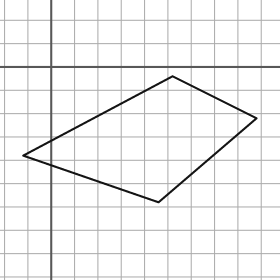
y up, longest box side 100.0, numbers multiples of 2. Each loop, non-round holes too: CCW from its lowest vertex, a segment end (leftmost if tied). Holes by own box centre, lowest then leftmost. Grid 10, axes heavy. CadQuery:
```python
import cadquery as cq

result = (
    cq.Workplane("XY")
    .moveTo(46.0, -58.0)
    .lineTo(88.0, -22.0)
    .lineTo(52.0, -4.0)
    .lineTo(-12.0, -38.0)
    .close()
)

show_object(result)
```